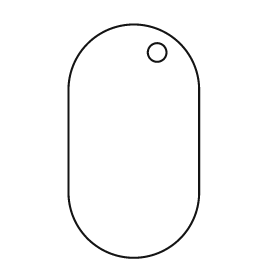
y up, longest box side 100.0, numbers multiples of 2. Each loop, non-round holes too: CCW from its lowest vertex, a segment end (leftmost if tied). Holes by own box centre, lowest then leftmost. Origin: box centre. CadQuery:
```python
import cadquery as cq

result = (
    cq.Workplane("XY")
    .moveTo(-28.0, -22.0)
    .threePointArc((0.0, -50.0), (28.0, -22.0))
    .lineTo(28.0, 22.0)
    .threePointArc((0.0, 50.0), (-28.0, 22.0))
    .close()
    .moveTo(10.0, 38.0)
    .circle(4.0)
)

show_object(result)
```